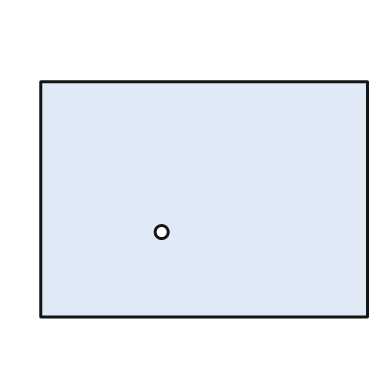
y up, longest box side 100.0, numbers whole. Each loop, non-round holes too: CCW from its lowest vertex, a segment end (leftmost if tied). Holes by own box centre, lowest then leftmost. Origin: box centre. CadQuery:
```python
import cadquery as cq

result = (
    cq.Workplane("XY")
    .moveTo(-50.0, -36.0)
    .lineTo(50.0, -36.0)
    .lineTo(50.0, 36.0)
    .lineTo(-50.0, 36.0)
    .close()
    .moveTo(-13.0, -10.0)
    .circle(2.0)
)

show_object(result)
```